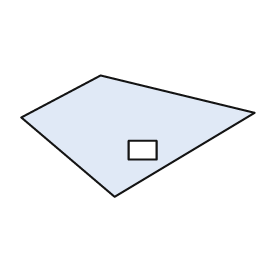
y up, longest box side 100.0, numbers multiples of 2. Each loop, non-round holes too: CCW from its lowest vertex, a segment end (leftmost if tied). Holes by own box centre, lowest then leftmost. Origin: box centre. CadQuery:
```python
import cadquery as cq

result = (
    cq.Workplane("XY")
    .moveTo(-10.0, -26.0)
    .lineTo(50.0, 10.0)
    .lineTo(-16.0, 26.0)
    .lineTo(-50.0, 8.0)
    .close()
    .moveTo(-4.0, -10.0)
    .lineTo(8.0, -10.0)
    .lineTo(8.0, -2.0)
    .lineTo(-4.0, -2.0)
    .close()
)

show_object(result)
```